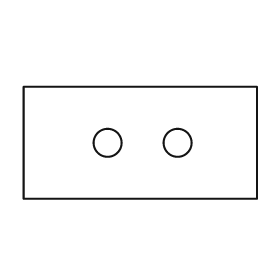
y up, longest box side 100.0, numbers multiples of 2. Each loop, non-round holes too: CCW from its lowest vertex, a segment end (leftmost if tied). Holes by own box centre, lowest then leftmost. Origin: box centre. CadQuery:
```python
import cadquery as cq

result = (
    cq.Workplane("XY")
    .moveTo(-50.0, -24.0)
    .lineTo(50.0, -24.0)
    .lineTo(50.0, 24.0)
    .lineTo(-50.0, 24.0)
    .close()
    .moveTo(-14.0, 0.0)
    .circle(6.0)
    .moveTo(16.0, 0.0)
    .circle(6.0)
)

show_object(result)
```